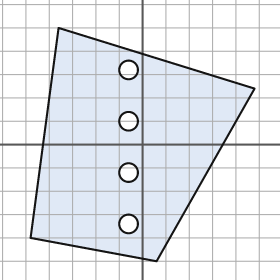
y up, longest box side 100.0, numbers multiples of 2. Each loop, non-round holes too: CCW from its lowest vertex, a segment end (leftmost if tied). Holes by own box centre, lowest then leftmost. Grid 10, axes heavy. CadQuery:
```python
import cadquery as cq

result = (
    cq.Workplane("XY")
    .moveTo(6.0, -50.0)
    .lineTo(48.0, 24.0)
    .lineTo(-36.0, 50.0)
    .lineTo(-48.0, -40.0)
    .close()
    .moveTo(-6.0, -34.0)
    .circle(4.0)
    .moveTo(-6.0, -12.0)
    .circle(4.0)
    .moveTo(-6.0, 10.0)
    .circle(4.0)
    .moveTo(-6.0, 32.0)
    .circle(4.0)
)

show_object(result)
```